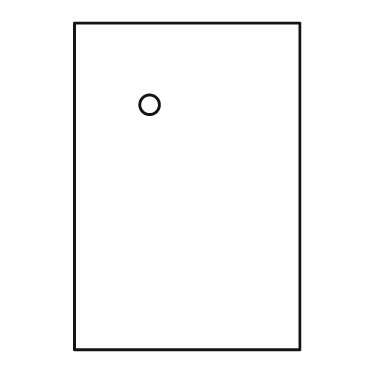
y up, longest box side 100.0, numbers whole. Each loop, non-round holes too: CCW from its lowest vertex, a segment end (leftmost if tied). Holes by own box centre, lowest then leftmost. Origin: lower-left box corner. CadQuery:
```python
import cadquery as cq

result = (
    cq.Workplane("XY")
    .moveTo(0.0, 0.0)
    .lineTo(69.0, 0.0)
    .lineTo(69.0, 100.0)
    .lineTo(0.0, 100.0)
    .close()
    .moveTo(23.0, 75.0)
    .circle(3.0)
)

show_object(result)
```